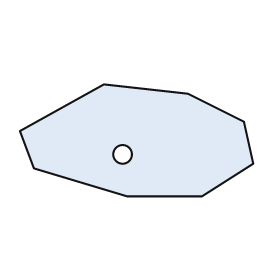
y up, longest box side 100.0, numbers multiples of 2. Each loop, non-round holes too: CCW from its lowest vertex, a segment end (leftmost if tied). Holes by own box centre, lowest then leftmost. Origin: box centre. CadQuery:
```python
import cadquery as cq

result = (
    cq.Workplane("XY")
    .moveTo(-4.0, -24.0)
    .lineTo(28.0, -24.0)
    .lineTo(50.0, -10.0)
    .lineTo(46.0, 8.0)
    .lineTo(22.0, 20.0)
    .lineTo(-14.0, 24.0)
    .lineTo(-50.0, 4.0)
    .lineTo(-44.0, -12.0)
    .close()
    .moveTo(-6.0, -6.0)
    .circle(4.0)
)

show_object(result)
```